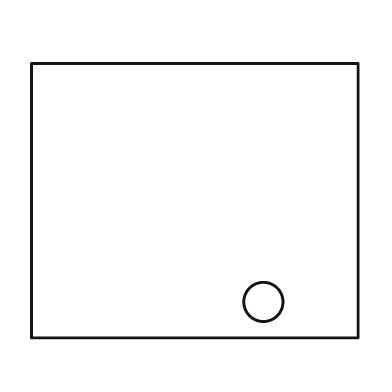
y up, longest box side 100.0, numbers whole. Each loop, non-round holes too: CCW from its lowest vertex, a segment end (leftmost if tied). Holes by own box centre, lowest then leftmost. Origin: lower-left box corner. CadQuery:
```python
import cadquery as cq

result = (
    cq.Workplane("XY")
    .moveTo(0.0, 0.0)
    .lineTo(100.0, 0.0)
    .lineTo(100.0, 84.0)
    .lineTo(0.0, 84.0)
    .close()
    .moveTo(71.0, 11.0)
    .circle(6.0)
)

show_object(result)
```